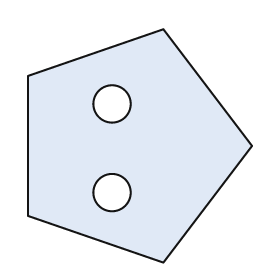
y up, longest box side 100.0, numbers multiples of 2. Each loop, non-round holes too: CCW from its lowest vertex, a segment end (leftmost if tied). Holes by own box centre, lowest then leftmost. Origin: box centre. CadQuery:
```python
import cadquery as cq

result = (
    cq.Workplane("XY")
    .moveTo(10.0, -50.0)
    .lineTo(48.0, 0.0)
    .lineTo(10.0, 50.0)
    .lineTo(-48.0, 30.0)
    .lineTo(-48.0, -30.0)
    .close()
    .moveTo(-12.0, -20.0)
    .circle(8.0)
    .moveTo(-12.0, 18.0)
    .circle(8.0)
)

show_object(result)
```